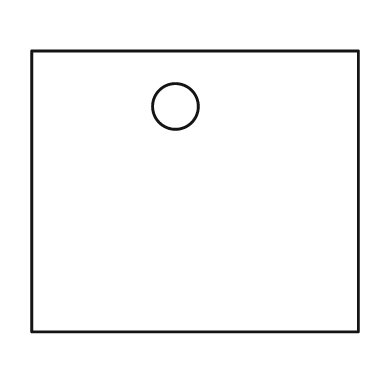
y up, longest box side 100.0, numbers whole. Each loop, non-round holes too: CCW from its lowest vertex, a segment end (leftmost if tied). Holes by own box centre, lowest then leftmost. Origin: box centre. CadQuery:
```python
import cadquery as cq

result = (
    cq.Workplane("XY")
    .moveTo(-50.0, -43.0)
    .lineTo(50.0, -43.0)
    .lineTo(50.0, 43.0)
    .lineTo(-50.0, 43.0)
    .close()
    .moveTo(-6.0, 26.0)
    .circle(7.0)
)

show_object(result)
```